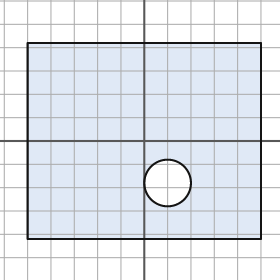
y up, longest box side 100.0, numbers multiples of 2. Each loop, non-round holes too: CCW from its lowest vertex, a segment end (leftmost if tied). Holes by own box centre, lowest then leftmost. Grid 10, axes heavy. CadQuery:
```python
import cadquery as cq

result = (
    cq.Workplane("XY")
    .moveTo(-50.0, -42.0)
    .lineTo(50.0, -42.0)
    .lineTo(50.0, 42.0)
    .lineTo(-50.0, 42.0)
    .close()
    .moveTo(10.0, -18.0)
    .circle(10.0)
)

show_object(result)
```